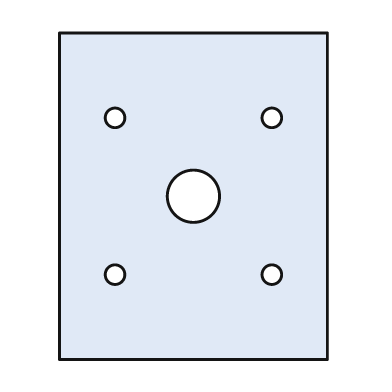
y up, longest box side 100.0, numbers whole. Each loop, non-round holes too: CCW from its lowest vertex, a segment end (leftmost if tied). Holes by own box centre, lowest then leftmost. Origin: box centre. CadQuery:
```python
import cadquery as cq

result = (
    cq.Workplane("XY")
    .moveTo(-41.0, -50.0)
    .lineTo(41.0, -50.0)
    .lineTo(41.0, 50.0)
    .lineTo(-41.0, 50.0)
    .close()
    .moveTo(-24.0, -24.0)
    .circle(3.0)
    .moveTo(24.0, -24.0)
    .circle(3.0)
    .moveTo(0.0, 0.0)
    .circle(8.0)
    .moveTo(-24.0, 24.0)
    .circle(3.0)
    .moveTo(24.0, 24.0)
    .circle(3.0)
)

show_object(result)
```